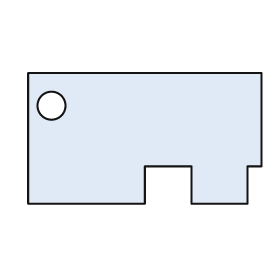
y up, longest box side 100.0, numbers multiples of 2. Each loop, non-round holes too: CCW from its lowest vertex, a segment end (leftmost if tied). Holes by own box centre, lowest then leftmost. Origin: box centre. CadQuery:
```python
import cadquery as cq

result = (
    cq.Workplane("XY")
    .moveTo(-50.0, -28.0)
    .lineTo(0.0, -28.0)
    .lineTo(0.0, -12.0)
    .lineTo(20.0, -12.0)
    .lineTo(20.0, -28.0)
    .lineTo(44.0, -28.0)
    .lineTo(44.0, -12.0)
    .lineTo(50.0, -12.0)
    .lineTo(50.0, 28.0)
    .lineTo(-50.0, 28.0)
    .close()
    .moveTo(-40.0, 14.0)
    .circle(6.0)
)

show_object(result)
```